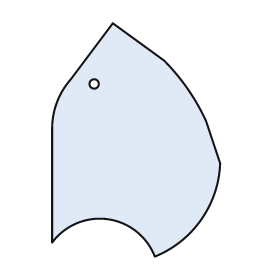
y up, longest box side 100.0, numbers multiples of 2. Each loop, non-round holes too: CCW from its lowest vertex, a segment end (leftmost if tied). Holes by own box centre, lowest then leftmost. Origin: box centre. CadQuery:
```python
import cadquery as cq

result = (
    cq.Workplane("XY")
    .moveTo(8.0, -50.0)
    .threePointArc((28.0, -34.0), (36.0, -10.0))
    .lineTo(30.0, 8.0)
    .threePointArc((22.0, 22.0), (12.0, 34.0))
    .lineTo(-10.0, 50.0)
    .lineTo(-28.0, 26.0)
    .threePointArc((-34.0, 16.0), (-36.0, 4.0))
    .lineTo(-36.0, -44.0)
    .threePointArc((-12.0, -34.0), (8.0, -50.0))
    .close()
    .moveTo(-18.0, 24.0)
    .circle(2.0)
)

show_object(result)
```